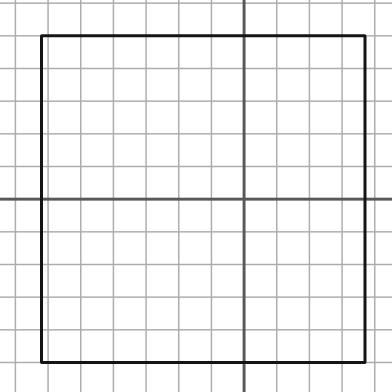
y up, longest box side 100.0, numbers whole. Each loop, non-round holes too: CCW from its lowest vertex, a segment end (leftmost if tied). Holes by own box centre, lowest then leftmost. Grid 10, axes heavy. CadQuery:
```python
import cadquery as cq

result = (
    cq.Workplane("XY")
    .moveTo(-62.0, -50.0)
    .lineTo(37.0, -50.0)
    .lineTo(37.0, 50.0)
    .lineTo(-62.0, 50.0)
    .close()
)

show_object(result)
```